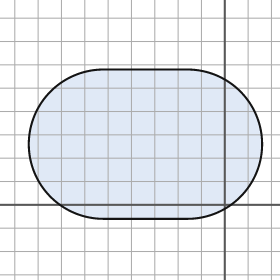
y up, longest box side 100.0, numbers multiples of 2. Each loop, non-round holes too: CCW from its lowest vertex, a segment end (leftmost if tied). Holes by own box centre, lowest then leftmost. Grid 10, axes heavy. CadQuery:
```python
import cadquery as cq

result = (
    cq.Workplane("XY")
    .moveTo(-52.0, -6.0)
    .lineTo(-16.0, -6.0)
    .threePointArc((16.0, 26.0), (-16.0, 58.0))
    .lineTo(-52.0, 58.0)
    .threePointArc((-84.0, 26.0), (-52.0, -6.0))
    .close()
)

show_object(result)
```